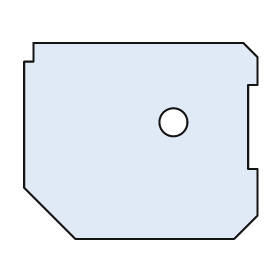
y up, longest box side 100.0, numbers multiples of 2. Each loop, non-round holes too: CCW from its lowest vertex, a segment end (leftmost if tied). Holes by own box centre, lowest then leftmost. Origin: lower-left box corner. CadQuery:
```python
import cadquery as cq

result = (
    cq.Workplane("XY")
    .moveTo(22.0, 0.0)
    .lineTo(90.0, 0.0)
    .lineTo(100.0, 10.0)
    .lineTo(100.0, 30.0)
    .lineTo(96.0, 30.0)
    .lineTo(96.0, 66.0)
    .lineTo(100.0, 66.0)
    .lineTo(100.0, 78.0)
    .lineTo(94.0, 84.0)
    .lineTo(4.0, 84.0)
    .lineTo(4.0, 76.0)
    .lineTo(0.0, 76.0)
    .lineTo(0.0, 22.0)
    .close()
    .moveTo(64.0, 50.0)
    .circle(6.0)
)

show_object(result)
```